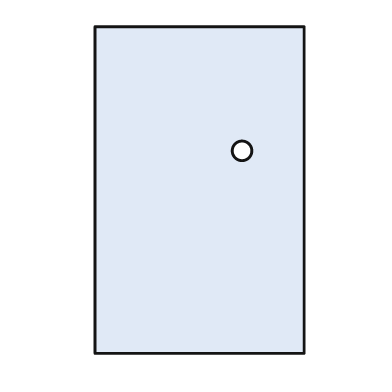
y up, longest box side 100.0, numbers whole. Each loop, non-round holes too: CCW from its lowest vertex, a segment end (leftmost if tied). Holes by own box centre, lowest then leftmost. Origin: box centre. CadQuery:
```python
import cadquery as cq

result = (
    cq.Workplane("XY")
    .moveTo(-32.0, -50.0)
    .lineTo(32.0, -50.0)
    .lineTo(32.0, 50.0)
    .lineTo(-32.0, 50.0)
    .close()
    .moveTo(13.0, 12.0)
    .circle(3.0)
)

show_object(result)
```